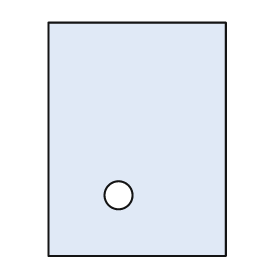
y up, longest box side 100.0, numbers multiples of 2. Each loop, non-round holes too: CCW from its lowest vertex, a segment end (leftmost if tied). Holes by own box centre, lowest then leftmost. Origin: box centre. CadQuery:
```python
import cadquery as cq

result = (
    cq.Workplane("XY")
    .moveTo(-38.0, -50.0)
    .lineTo(38.0, -50.0)
    .lineTo(38.0, 50.0)
    .lineTo(-38.0, 50.0)
    .close()
    .moveTo(-8.0, -24.0)
    .circle(6.0)
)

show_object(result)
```